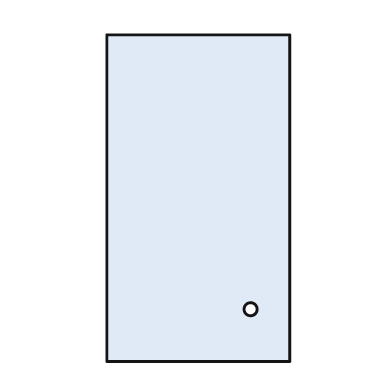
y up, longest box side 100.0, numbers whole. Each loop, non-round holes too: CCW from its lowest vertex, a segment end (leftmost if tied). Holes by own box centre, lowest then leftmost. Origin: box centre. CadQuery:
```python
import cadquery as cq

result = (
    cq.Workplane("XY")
    .moveTo(-28.0, -50.0)
    .lineTo(28.0, -50.0)
    .lineTo(28.0, 50.0)
    .lineTo(-28.0, 50.0)
    .close()
    .moveTo(16.0, -34.0)
    .circle(2.0)
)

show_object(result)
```